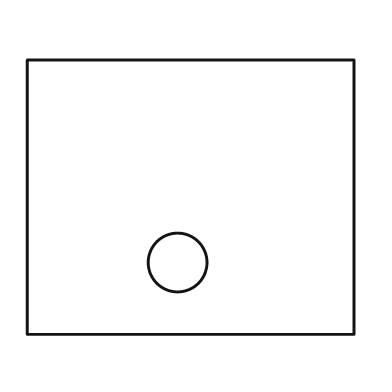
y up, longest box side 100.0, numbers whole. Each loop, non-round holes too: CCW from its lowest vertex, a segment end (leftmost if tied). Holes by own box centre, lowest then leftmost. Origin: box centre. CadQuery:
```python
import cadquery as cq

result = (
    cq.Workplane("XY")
    .moveTo(-50.0, -42.0)
    .lineTo(50.0, -42.0)
    .lineTo(50.0, 42.0)
    .lineTo(-50.0, 42.0)
    .close()
    .moveTo(-4.0, -20.0)
    .circle(9.0)
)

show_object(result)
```